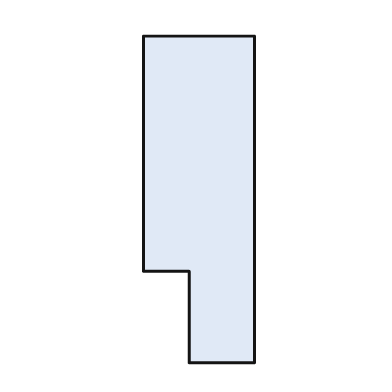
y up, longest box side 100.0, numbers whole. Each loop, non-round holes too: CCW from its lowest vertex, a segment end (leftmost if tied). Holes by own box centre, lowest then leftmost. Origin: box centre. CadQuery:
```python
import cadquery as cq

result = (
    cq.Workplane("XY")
    .moveTo(-3.0, -50.0)
    .lineTo(17.0, -50.0)
    .lineTo(17.0, 50.0)
    .lineTo(-17.0, 50.0)
    .lineTo(-17.0, -22.0)
    .lineTo(-3.0, -22.0)
    .close()
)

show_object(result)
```